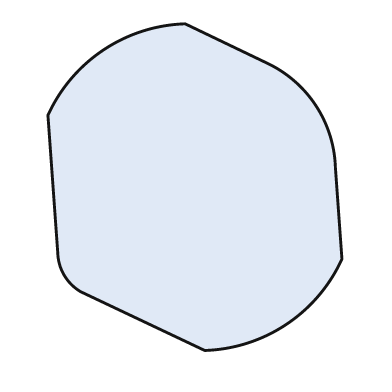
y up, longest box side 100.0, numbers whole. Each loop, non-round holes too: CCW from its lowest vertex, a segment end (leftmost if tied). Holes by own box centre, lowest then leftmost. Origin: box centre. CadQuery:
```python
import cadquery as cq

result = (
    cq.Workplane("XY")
    .moveTo(3.0, -50.0)
    .threePointArc((28.0, -42.0), (45.0, -22.0))
    .lineTo(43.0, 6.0)
    .threePointArc((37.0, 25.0), (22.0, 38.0))
    .lineTo(-3.0, 50.0)
    .threePointArc((-28.0, 42.0), (-45.0, 22.0))
    .lineTo(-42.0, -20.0)
    .threePointArc((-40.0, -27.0), (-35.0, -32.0))
    .close()
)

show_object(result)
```